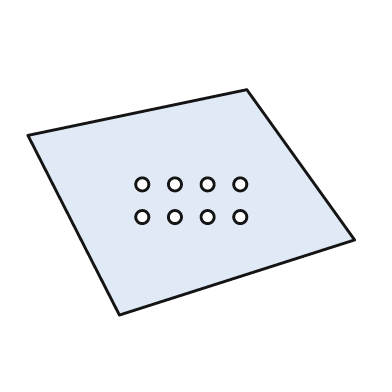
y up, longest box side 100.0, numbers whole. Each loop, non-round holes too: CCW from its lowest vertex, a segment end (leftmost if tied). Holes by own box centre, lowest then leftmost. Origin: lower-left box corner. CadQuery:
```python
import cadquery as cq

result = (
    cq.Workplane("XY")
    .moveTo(28.0, 0.0)
    .lineTo(100.0, 23.0)
    .lineTo(67.0, 69.0)
    .lineTo(0.0, 55.0)
    .close()
    .moveTo(35.0, 30.0)
    .circle(2.0)
    .moveTo(45.0, 30.0)
    .circle(2.0)
    .moveTo(55.0, 30.0)
    .circle(2.0)
    .moveTo(65.0, 30.0)
    .circle(2.0)
    .moveTo(35.0, 40.0)
    .circle(2.0)
    .moveTo(45.0, 40.0)
    .circle(2.0)
    .moveTo(55.0, 40.0)
    .circle(2.0)
    .moveTo(65.0, 40.0)
    .circle(2.0)
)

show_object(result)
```